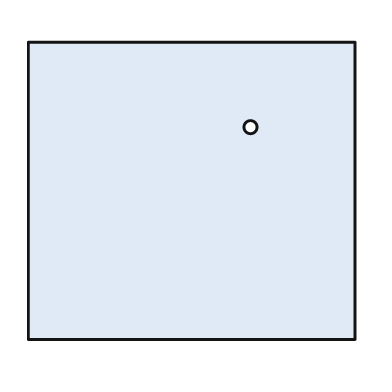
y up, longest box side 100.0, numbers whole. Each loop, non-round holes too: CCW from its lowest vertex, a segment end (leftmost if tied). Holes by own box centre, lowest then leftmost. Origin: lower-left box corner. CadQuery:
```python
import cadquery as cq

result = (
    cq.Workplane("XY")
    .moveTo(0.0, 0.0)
    .lineTo(100.0, 0.0)
    .lineTo(100.0, 91.0)
    .lineTo(0.0, 91.0)
    .close()
    .moveTo(68.0, 65.0)
    .circle(2.0)
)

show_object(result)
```